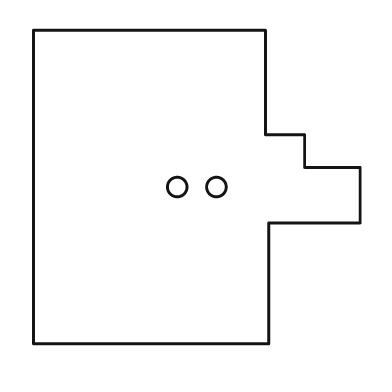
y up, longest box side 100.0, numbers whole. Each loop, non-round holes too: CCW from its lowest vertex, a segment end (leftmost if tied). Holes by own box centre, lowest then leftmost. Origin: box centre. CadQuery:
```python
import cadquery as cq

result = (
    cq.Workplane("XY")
    .moveTo(-50.0, -48.0)
    .lineTo(22.0, -48.0)
    .lineTo(22.0, -11.0)
    .lineTo(50.0, -11.0)
    .lineTo(50.0, 6.0)
    .lineTo(33.0, 6.0)
    .lineTo(33.0, 16.0)
    .lineTo(21.0, 16.0)
    .lineTo(21.0, 48.0)
    .lineTo(-50.0, 48.0)
    .close()
    .moveTo(-6.0, 0.0)
    .circle(3.0)
    .moveTo(6.0, 0.0)
    .circle(3.0)
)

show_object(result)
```